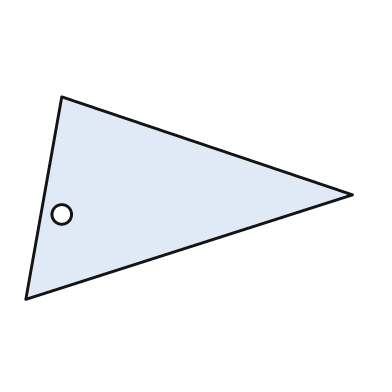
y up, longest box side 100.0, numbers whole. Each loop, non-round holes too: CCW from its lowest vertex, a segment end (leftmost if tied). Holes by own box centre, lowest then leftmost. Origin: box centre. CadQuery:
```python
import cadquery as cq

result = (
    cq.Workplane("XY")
    .moveTo(-50.0, -31.0)
    .lineTo(50.0, 1.0)
    .lineTo(-39.0, 31.0)
    .close()
    .moveTo(-39.0, -5.0)
    .circle(3.0)
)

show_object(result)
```